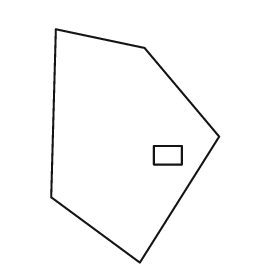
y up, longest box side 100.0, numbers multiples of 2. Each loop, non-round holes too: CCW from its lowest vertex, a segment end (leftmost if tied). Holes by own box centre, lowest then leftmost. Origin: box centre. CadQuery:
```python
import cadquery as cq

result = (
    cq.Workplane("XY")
    .moveTo(2.0, -50.0)
    .lineTo(36.0, 4.0)
    .lineTo(4.0, 42.0)
    .lineTo(-34.0, 50.0)
    .lineTo(-36.0, -22.0)
    .close()
    .moveTo(8.0, -8.0)
    .lineTo(20.0, -8.0)
    .lineTo(20.0, 0.0)
    .lineTo(8.0, 0.0)
    .close()
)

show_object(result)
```